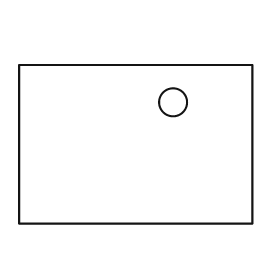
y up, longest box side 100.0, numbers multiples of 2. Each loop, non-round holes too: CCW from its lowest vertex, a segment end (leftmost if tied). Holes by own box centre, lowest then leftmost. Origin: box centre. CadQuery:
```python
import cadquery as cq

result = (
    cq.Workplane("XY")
    .moveTo(-50.0, -34.0)
    .lineTo(50.0, -34.0)
    .lineTo(50.0, 34.0)
    .lineTo(-50.0, 34.0)
    .close()
    .moveTo(16.0, 18.0)
    .circle(6.0)
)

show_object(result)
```